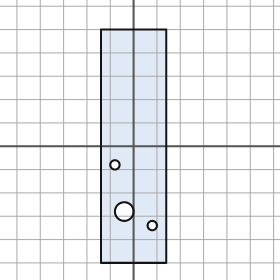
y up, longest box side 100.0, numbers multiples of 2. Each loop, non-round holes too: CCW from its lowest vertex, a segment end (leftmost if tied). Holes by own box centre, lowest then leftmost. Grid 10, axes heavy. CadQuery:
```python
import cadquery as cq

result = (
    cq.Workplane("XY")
    .moveTo(-14.0, -50.0)
    .lineTo(14.0, -50.0)
    .lineTo(14.0, 50.0)
    .lineTo(-14.0, 50.0)
    .close()
    .moveTo(8.0, -34.0)
    .circle(2.0)
    .moveTo(-4.0, -28.0)
    .circle(4.0)
    .moveTo(-8.0, -8.0)
    .circle(2.0)
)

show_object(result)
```